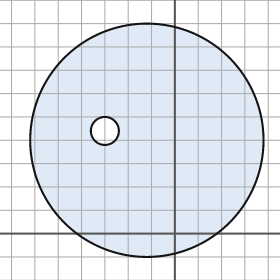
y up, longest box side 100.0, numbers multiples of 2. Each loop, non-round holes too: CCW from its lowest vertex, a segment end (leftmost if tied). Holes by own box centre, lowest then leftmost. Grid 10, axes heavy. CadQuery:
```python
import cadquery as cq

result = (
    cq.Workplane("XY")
    .moveTo(-12.0, 40.0)
    .circle(50.0)
    .moveTo(-30.0, 44.0)
    .circle(6.0)
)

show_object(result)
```